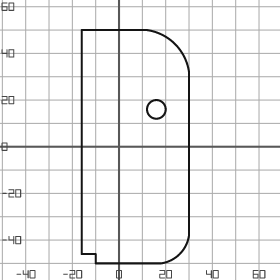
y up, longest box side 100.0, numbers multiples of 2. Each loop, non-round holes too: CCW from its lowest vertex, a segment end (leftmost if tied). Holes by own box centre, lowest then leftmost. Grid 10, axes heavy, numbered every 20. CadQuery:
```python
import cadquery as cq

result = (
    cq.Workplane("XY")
    .moveTo(-10.0, -50.0)
    .lineTo(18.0, -50.0)
    .threePointArc((26.0, -46.0), (30.0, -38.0))
    .lineTo(30.0, 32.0)
    .threePointArc((24.0, 44.0), (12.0, 50.0))
    .lineTo(-16.0, 50.0)
    .lineTo(-16.0, -46.0)
    .lineTo(-10.0, -46.0)
    .close()
    .moveTo(16.0, 16.0)
    .circle(4.0)
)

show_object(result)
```